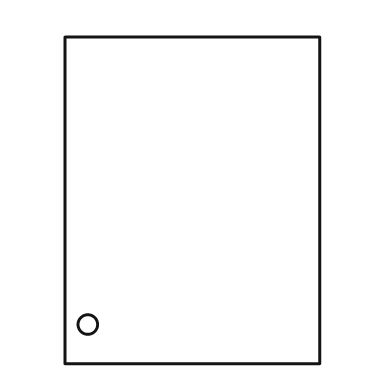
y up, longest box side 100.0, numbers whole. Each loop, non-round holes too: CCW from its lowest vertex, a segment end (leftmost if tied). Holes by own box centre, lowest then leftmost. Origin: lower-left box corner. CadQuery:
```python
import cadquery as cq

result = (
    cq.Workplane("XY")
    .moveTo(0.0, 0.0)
    .lineTo(78.0, 0.0)
    .lineTo(78.0, 100.0)
    .lineTo(0.0, 100.0)
    .close()
    .moveTo(7.0, 12.0)
    .circle(3.0)
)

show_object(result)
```